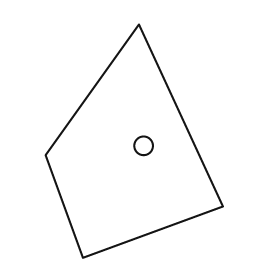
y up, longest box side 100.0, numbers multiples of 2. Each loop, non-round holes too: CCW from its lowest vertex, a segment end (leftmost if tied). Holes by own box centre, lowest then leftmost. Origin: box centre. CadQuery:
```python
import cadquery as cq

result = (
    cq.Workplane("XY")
    .moveTo(-22.0, -50.0)
    .lineTo(38.0, -28.0)
    .lineTo(2.0, 50.0)
    .lineTo(-38.0, -6.0)
    .close()
    .moveTo(4.0, -2.0)
    .circle(4.0)
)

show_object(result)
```